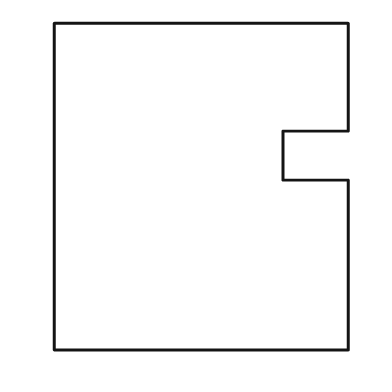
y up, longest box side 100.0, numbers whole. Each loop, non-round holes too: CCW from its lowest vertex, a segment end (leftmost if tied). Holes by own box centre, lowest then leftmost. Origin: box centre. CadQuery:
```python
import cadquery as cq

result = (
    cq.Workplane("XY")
    .moveTo(-45.0, -50.0)
    .lineTo(45.0, -50.0)
    .lineTo(45.0, 2.0)
    .lineTo(25.0, 2.0)
    .lineTo(25.0, 17.0)
    .lineTo(45.0, 17.0)
    .lineTo(45.0, 50.0)
    .lineTo(-45.0, 50.0)
    .close()
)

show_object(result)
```